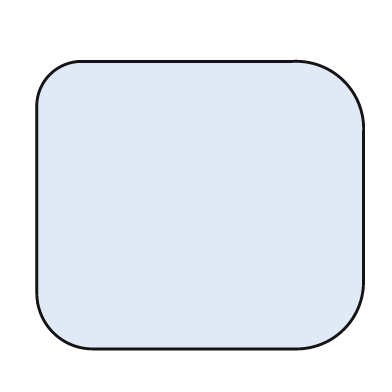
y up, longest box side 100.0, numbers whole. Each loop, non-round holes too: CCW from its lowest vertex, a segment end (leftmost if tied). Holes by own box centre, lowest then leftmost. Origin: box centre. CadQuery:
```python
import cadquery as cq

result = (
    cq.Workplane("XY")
    .moveTo(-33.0, -44.0)
    .lineTo(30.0, -44.0)
    .threePointArc((44.0, -38.0), (50.0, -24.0))
    .lineTo(50.0, 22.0)
    .threePointArc((44.0, 38.0), (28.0, 44.0))
    .lineTo(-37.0, 44.0)
    .threePointArc((-46.0, 40.0), (-50.0, 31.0))
    .lineTo(-50.0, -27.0)
    .threePointArc((-45.0, -39.0), (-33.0, -44.0))
    .close()
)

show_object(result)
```